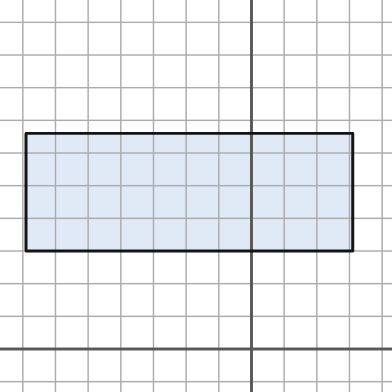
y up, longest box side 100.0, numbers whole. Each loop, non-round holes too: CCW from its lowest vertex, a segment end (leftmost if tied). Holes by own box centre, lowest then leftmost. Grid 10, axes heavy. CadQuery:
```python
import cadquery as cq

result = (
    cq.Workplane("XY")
    .moveTo(-69.0, 30.0)
    .lineTo(31.0, 30.0)
    .lineTo(31.0, 66.0)
    .lineTo(-69.0, 66.0)
    .close()
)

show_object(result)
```